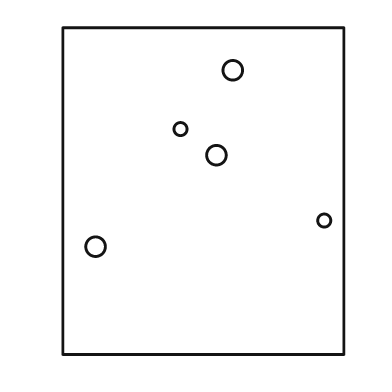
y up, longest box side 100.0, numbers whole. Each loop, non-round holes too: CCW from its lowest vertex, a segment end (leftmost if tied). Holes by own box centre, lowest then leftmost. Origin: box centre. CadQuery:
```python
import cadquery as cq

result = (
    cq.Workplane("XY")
    .moveTo(-43.0, -50.0)
    .lineTo(43.0, -50.0)
    .lineTo(43.0, 50.0)
    .lineTo(-43.0, 50.0)
    .close()
    .moveTo(-33.0, -17.0)
    .circle(3.0)
    .moveTo(37.0, -9.0)
    .circle(2.0)
    .moveTo(4.0, 11.0)
    .circle(3.0)
    .moveTo(-7.0, 19.0)
    .circle(2.0)
    .moveTo(9.0, 37.0)
    .circle(3.0)
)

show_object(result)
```